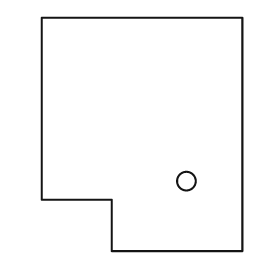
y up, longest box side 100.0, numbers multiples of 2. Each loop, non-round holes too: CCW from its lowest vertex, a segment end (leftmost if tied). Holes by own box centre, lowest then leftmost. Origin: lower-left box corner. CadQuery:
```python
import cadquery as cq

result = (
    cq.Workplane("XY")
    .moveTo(30.0, 0.0)
    .lineTo(86.0, 0.0)
    .lineTo(86.0, 100.0)
    .lineTo(0.0, 100.0)
    .lineTo(0.0, 22.0)
    .lineTo(30.0, 22.0)
    .close()
    .moveTo(62.0, 30.0)
    .circle(4.0)
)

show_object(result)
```